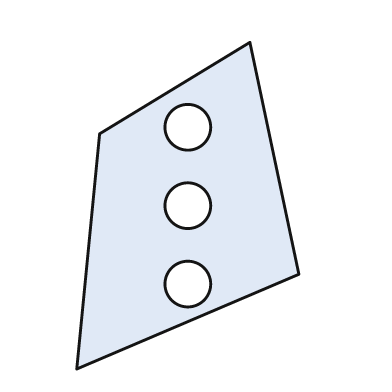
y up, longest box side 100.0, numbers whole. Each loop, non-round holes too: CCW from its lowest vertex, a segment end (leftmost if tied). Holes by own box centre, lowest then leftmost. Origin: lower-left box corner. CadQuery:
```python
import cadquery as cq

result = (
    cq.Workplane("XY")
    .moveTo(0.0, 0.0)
    .lineTo(68.0, 29.0)
    .lineTo(53.0, 100.0)
    .lineTo(7.0, 72.0)
    .close()
    .moveTo(34.0, 26.0)
    .circle(7.0)
    .moveTo(34.0, 50.0)
    .circle(7.0)
    .moveTo(34.0, 74.0)
    .circle(7.0)
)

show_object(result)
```